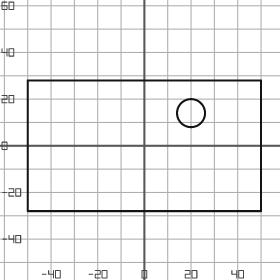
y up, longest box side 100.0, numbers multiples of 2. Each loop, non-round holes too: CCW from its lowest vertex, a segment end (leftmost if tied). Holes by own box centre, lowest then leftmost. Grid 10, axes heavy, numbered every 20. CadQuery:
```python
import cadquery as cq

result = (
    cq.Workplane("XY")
    .moveTo(-50.0, -28.0)
    .lineTo(50.0, -28.0)
    .lineTo(50.0, 28.0)
    .lineTo(-50.0, 28.0)
    .close()
    .moveTo(20.0, 14.0)
    .circle(6.0)
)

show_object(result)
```